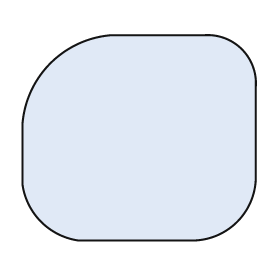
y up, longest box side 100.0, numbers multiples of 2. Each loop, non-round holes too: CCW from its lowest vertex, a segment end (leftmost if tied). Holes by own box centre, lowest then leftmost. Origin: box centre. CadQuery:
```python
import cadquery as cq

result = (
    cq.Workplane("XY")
    .moveTo(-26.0, -44.0)
    .lineTo(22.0, -44.0)
    .threePointArc((42.0, -36.0), (50.0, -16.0))
    .lineTo(50.0, 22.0)
    .threePointArc((44.0, 38.0), (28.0, 44.0))
    .lineTo(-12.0, 44.0)
    .threePointArc((-38.0, 32.0), (-50.0, 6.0))
    .lineTo(-50.0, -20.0)
    .threePointArc((-42.0, -36.0), (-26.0, -44.0))
    .close()
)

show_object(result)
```